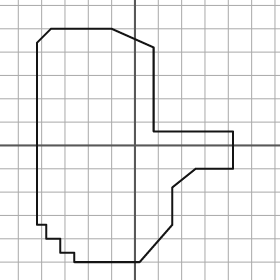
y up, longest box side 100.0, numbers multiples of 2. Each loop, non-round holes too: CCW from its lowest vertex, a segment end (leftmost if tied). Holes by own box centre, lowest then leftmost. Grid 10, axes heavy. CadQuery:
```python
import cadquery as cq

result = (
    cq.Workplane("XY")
    .moveTo(-26.0, -50.0)
    .lineTo(2.0, -50.0)
    .lineTo(16.0, -34.0)
    .lineTo(16.0, -18.0)
    .lineTo(26.0, -10.0)
    .lineTo(42.0, -10.0)
    .lineTo(42.0, 6.0)
    .lineTo(8.0, 6.0)
    .lineTo(8.0, 42.0)
    .lineTo(-10.0, 50.0)
    .lineTo(-36.0, 50.0)
    .lineTo(-42.0, 44.0)
    .lineTo(-42.0, -34.0)
    .lineTo(-38.0, -34.0)
    .lineTo(-38.0, -40.0)
    .lineTo(-32.0, -40.0)
    .lineTo(-32.0, -46.0)
    .lineTo(-26.0, -46.0)
    .close()
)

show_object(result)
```